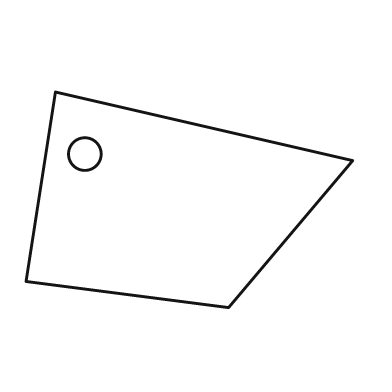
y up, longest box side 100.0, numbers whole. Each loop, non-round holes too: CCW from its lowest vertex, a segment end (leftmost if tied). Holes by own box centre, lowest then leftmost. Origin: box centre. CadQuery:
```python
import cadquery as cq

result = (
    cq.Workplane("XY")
    .moveTo(12.0, -33.0)
    .lineTo(50.0, 12.0)
    .lineTo(-41.0, 33.0)
    .lineTo(-50.0, -25.0)
    .close()
    .moveTo(-32.0, 14.0)
    .circle(5.0)
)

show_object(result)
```